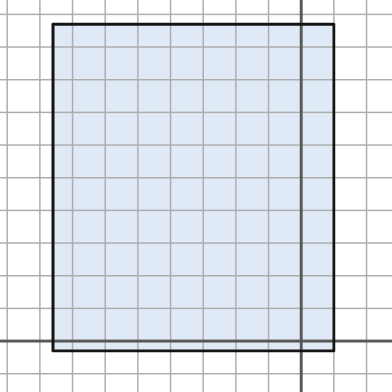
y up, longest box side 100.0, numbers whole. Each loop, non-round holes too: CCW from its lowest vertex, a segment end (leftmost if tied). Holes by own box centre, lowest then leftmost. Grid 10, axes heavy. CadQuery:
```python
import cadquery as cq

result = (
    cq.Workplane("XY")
    .moveTo(-76.0, -3.0)
    .lineTo(10.0, -3.0)
    .lineTo(10.0, 97.0)
    .lineTo(-76.0, 97.0)
    .close()
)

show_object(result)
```